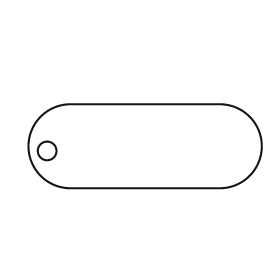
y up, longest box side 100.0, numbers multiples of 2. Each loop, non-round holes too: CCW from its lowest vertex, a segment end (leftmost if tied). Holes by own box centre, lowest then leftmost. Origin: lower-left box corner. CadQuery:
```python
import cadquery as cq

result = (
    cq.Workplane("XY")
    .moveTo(18.0, 0.0)
    .lineTo(82.0, 0.0)
    .threePointArc((100.0, 18.0), (82.0, 36.0))
    .lineTo(18.0, 36.0)
    .threePointArc((0.0, 18.0), (18.0, 0.0))
    .close()
    .moveTo(8.0, 16.0)
    .circle(4.0)
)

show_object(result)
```